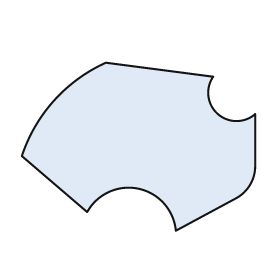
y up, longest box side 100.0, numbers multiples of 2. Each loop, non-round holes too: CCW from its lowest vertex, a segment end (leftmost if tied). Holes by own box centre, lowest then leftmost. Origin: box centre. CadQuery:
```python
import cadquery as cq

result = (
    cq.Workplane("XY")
    .moveTo(16.0, -36.0)
    .lineTo(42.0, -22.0)
    .threePointArc((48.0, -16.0), (50.0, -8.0))
    .lineTo(50.0, 14.0)
    .threePointArc((34.0, 14.0), (32.0, 30.0))
    .lineTo(-14.0, 36.0)
    .threePointArc((-36.0, 20.0), (-50.0, -4.0))
    .lineTo(-22.0, -28.0)
    .threePointArc((0.0, -18.0), (16.0, -36.0))
    .close()
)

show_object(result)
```